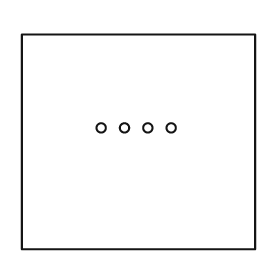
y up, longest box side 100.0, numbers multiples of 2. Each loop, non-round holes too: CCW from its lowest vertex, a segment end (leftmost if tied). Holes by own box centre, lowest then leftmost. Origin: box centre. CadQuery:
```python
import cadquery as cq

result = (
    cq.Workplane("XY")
    .moveTo(-50.0, -46.0)
    .lineTo(50.0, -46.0)
    .lineTo(50.0, 46.0)
    .lineTo(-50.0, 46.0)
    .close()
    .moveTo(-16.0, 6.0)
    .circle(2.0)
    .moveTo(-6.0, 6.0)
    .circle(2.0)
    .moveTo(4.0, 6.0)
    .circle(2.0)
    .moveTo(14.0, 6.0)
    .circle(2.0)
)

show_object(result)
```